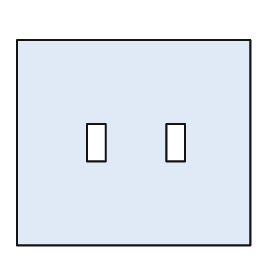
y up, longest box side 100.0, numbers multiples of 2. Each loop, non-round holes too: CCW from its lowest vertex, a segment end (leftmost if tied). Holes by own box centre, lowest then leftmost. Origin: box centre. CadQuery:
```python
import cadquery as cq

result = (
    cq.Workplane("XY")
    .moveTo(-50.0, -44.0)
    .lineTo(50.0, -44.0)
    .lineTo(50.0, 44.0)
    .lineTo(-50.0, 44.0)
    .close()
    .moveTo(-20.0, -8.0)
    .lineTo(-12.0, -8.0)
    .lineTo(-12.0, 8.0)
    .lineTo(-20.0, 8.0)
    .close()
    .moveTo(14.0, -8.0)
    .lineTo(22.0, -8.0)
    .lineTo(22.0, 8.0)
    .lineTo(14.0, 8.0)
    .close()
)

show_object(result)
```